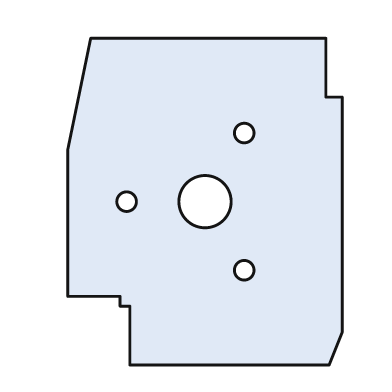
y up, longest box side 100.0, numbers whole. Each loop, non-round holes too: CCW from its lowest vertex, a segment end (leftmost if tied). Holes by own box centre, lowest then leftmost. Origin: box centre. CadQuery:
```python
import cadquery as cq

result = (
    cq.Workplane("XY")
    .moveTo(-23.0, -50.0)
    .lineTo(38.0, -50.0)
    .lineTo(42.0, -40.0)
    .lineTo(42.0, 32.0)
    .lineTo(37.0, 32.0)
    .lineTo(37.0, 50.0)
    .lineTo(-35.0, 50.0)
    .lineTo(-42.0, 16.0)
    .lineTo(-42.0, -29.0)
    .lineTo(-26.0, -29.0)
    .lineTo(-26.0, -32.0)
    .lineTo(-23.0, -32.0)
    .close()
    .moveTo(12.0, -21.0)
    .circle(3.0)
    .moveTo(-24.0, 0.0)
    .circle(3.0)
    .moveTo(0.0, 0.0)
    .circle(8.0)
    .moveTo(12.0, 21.0)
    .circle(3.0)
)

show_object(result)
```